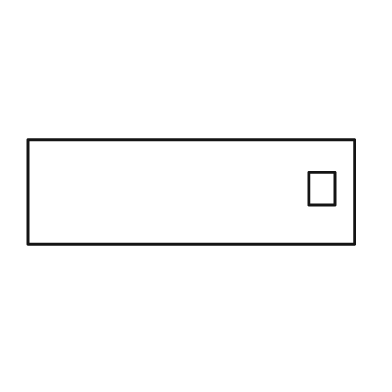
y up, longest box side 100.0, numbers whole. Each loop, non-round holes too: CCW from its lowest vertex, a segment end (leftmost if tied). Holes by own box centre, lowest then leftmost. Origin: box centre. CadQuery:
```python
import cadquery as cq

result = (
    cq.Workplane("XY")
    .moveTo(-50.0, -16.0)
    .lineTo(50.0, -16.0)
    .lineTo(50.0, 16.0)
    .lineTo(-50.0, 16.0)
    .close()
    .moveTo(36.0, -4.0)
    .lineTo(44.0, -4.0)
    .lineTo(44.0, 6.0)
    .lineTo(36.0, 6.0)
    .close()
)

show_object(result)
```